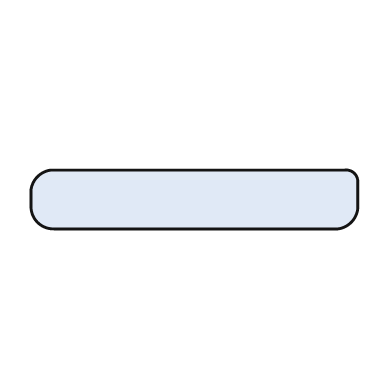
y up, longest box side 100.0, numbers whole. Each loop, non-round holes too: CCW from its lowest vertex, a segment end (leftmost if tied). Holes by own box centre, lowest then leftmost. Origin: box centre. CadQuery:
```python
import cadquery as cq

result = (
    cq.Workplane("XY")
    .moveTo(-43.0, -9.0)
    .lineTo(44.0, -9.0)
    .threePointArc((48.0, -7.0), (50.0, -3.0))
    .lineTo(50.0, 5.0)
    .threePointArc((49.0, 8.0), (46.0, 9.0))
    .lineTo(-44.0, 9.0)
    .threePointArc((-48.0, 7.0), (-50.0, 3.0))
    .lineTo(-50.0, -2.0)
    .threePointArc((-48.0, -7.0), (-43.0, -9.0))
    .close()
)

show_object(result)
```